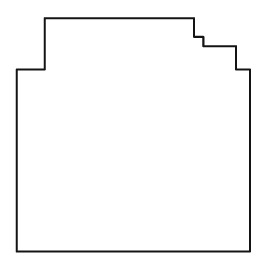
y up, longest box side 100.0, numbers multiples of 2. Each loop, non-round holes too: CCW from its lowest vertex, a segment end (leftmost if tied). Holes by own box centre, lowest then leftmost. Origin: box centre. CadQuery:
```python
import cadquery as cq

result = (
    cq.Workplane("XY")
    .moveTo(-50.0, -50.0)
    .lineTo(50.0, -50.0)
    .lineTo(50.0, 28.0)
    .lineTo(44.0, 28.0)
    .lineTo(44.0, 38.0)
    .lineTo(30.0, 38.0)
    .lineTo(30.0, 42.0)
    .lineTo(26.0, 42.0)
    .lineTo(26.0, 50.0)
    .lineTo(-38.0, 50.0)
    .lineTo(-38.0, 28.0)
    .lineTo(-50.0, 28.0)
    .close()
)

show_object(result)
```